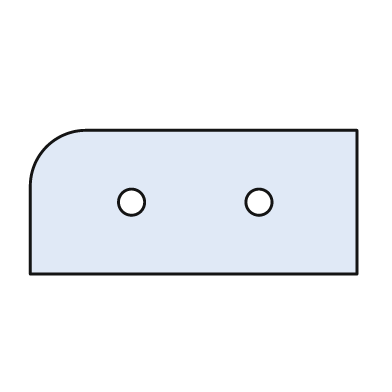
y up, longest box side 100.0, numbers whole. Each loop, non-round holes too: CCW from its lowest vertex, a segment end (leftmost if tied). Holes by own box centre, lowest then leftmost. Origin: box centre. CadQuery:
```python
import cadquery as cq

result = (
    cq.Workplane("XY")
    .moveTo(-50.0, -22.0)
    .lineTo(50.0, -22.0)
    .lineTo(50.0, 22.0)
    .lineTo(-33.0, 22.0)
    .threePointArc((-45.0, 17.0), (-50.0, 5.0))
    .close()
    .moveTo(-19.0, 0.0)
    .circle(4.0)
    .moveTo(20.0, 0.0)
    .circle(4.0)
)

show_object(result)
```